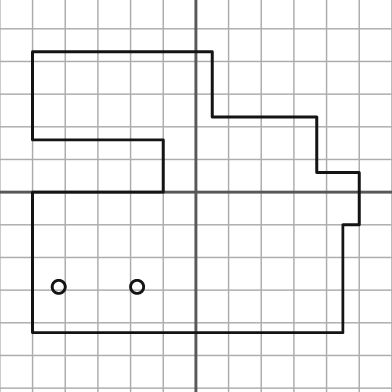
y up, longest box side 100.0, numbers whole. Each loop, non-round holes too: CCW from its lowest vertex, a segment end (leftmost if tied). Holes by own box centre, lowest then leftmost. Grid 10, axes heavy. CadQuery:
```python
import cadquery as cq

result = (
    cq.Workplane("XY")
    .moveTo(-50.0, -43.0)
    .lineTo(45.0, -43.0)
    .lineTo(45.0, -10.0)
    .lineTo(50.0, -10.0)
    .lineTo(50.0, 6.0)
    .lineTo(37.0, 6.0)
    .lineTo(37.0, 23.0)
    .lineTo(5.0, 23.0)
    .lineTo(5.0, 43.0)
    .lineTo(-50.0, 43.0)
    .lineTo(-50.0, 16.0)
    .lineTo(-10.0, 16.0)
    .lineTo(-10.0, 0.0)
    .lineTo(-50.0, 0.0)
    .close()
    .moveTo(-42.0, -29.0)
    .circle(2.0)
    .moveTo(-18.0, -29.0)
    .circle(2.0)
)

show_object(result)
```